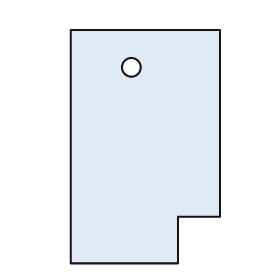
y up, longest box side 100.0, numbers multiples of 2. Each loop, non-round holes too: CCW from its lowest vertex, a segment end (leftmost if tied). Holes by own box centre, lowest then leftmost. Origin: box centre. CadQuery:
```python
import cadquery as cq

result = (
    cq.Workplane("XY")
    .moveTo(-32.0, -50.0)
    .lineTo(14.0, -50.0)
    .lineTo(14.0, -30.0)
    .lineTo(32.0, -30.0)
    .lineTo(32.0, 50.0)
    .lineTo(-32.0, 50.0)
    .close()
    .moveTo(-6.0, 34.0)
    .circle(4.0)
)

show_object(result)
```